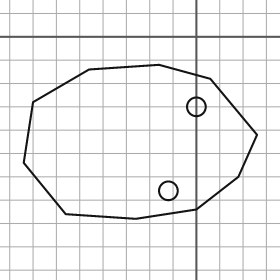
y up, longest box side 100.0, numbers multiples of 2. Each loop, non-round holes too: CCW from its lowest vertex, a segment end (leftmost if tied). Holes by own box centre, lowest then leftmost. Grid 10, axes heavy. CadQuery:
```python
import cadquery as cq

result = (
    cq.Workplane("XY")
    .moveTo(-26.0, -78.0)
    .lineTo(0.0, -74.0)
    .lineTo(18.0, -60.0)
    .lineTo(26.0, -42.0)
    .lineTo(6.0, -18.0)
    .lineTo(-16.0, -12.0)
    .lineTo(-46.0, -14.0)
    .lineTo(-70.0, -28.0)
    .lineTo(-74.0, -54.0)
    .lineTo(-56.0, -76.0)
    .close()
    .moveTo(-12.0, -66.0)
    .circle(4.0)
    .moveTo(0.0, -30.0)
    .circle(4.0)
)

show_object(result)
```